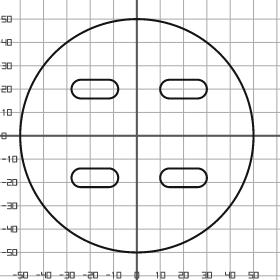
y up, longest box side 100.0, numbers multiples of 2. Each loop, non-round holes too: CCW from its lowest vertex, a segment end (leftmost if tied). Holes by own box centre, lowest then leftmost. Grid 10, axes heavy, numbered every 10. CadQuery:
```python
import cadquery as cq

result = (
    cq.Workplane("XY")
    .moveTo(0.0, 0.0)
    .circle(50.0)
    .moveTo(-24.0, -22.0)
    .lineTo(-12.0, -22.0)
    .threePointArc((-8.0, -18.0), (-12.0, -14.0))
    .lineTo(-24.0, -14.0)
    .threePointArc((-28.0, -18.0), (-24.0, -22.0))
    .close()
    .moveTo(14.0, -22.0)
    .lineTo(26.0, -22.0)
    .threePointArc((30.0, -18.0), (26.0, -14.0))
    .lineTo(14.0, -14.0)
    .threePointArc((10.0, -18.0), (14.0, -22.0))
    .close()
    .moveTo(-24.0, 16.0)
    .lineTo(-12.0, 16.0)
    .threePointArc((-8.0, 20.0), (-12.0, 24.0))
    .lineTo(-24.0, 24.0)
    .threePointArc((-28.0, 20.0), (-24.0, 16.0))
    .close()
    .moveTo(14.0, 16.0)
    .lineTo(26.0, 16.0)
    .threePointArc((30.0, 20.0), (26.0, 24.0))
    .lineTo(14.0, 24.0)
    .threePointArc((10.0, 20.0), (14.0, 16.0))
    .close()
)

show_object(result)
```